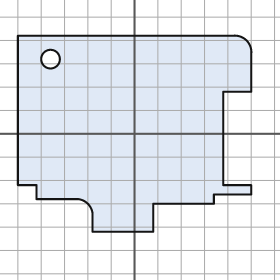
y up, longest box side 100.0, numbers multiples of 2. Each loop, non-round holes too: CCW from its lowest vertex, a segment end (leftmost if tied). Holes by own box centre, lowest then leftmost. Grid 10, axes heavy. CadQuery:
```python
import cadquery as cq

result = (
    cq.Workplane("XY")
    .moveTo(-18.0, -42.0)
    .lineTo(8.0, -42.0)
    .lineTo(8.0, -30.0)
    .lineTo(34.0, -30.0)
    .lineTo(34.0, -26.0)
    .lineTo(50.0, -26.0)
    .lineTo(50.0, -22.0)
    .lineTo(38.0, -22.0)
    .lineTo(38.0, 18.0)
    .lineTo(50.0, 18.0)
    .lineTo(50.0, 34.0)
    .threePointArc((48.0, 40.0), (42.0, 42.0))
    .lineTo(-50.0, 42.0)
    .lineTo(-50.0, -22.0)
    .lineTo(-42.0, -22.0)
    .lineTo(-42.0, -28.0)
    .lineTo(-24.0, -28.0)
    .threePointArc((-20.0, -30.0), (-18.0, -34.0))
    .close()
    .moveTo(-36.0, 32.0)
    .circle(4.0)
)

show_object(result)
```